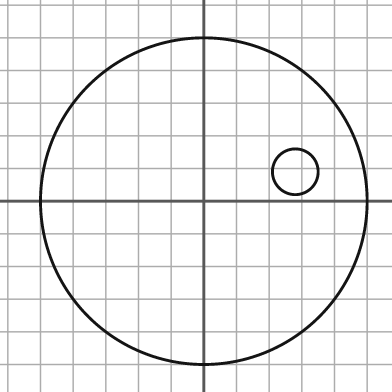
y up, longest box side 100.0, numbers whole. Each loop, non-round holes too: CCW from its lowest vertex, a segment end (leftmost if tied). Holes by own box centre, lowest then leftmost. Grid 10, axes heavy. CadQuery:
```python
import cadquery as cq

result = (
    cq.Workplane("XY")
    .moveTo(0.0, 0.0)
    .circle(50.0)
    .moveTo(28.0, 9.0)
    .circle(7.0)
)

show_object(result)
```